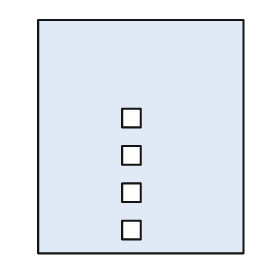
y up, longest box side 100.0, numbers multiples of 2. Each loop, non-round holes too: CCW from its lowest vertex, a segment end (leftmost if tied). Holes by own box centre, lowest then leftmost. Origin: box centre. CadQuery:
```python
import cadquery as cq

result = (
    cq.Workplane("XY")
    .moveTo(-44.0, -50.0)
    .lineTo(44.0, -50.0)
    .lineTo(44.0, 50.0)
    .lineTo(-44.0, 50.0)
    .close()
    .moveTo(-8.0, -44.0)
    .lineTo(0.0, -44.0)
    .lineTo(0.0, -36.0)
    .lineTo(-8.0, -36.0)
    .close()
    .moveTo(-8.0, -28.0)
    .lineTo(0.0, -28.0)
    .lineTo(0.0, -20.0)
    .lineTo(-8.0, -20.0)
    .close()
    .moveTo(-8.0, -12.0)
    .lineTo(0.0, -12.0)
    .lineTo(0.0, -4.0)
    .lineTo(-8.0, -4.0)
    .close()
    .moveTo(-8.0, 4.0)
    .lineTo(0.0, 4.0)
    .lineTo(0.0, 12.0)
    .lineTo(-8.0, 12.0)
    .close()
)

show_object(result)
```